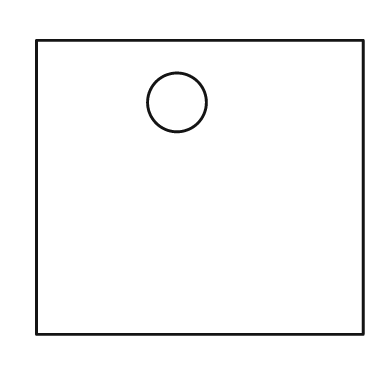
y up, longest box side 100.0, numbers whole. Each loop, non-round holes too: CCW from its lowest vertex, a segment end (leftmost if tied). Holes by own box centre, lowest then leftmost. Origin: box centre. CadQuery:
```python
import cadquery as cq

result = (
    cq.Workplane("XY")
    .moveTo(-50.0, -45.0)
    .lineTo(50.0, -45.0)
    .lineTo(50.0, 45.0)
    .lineTo(-50.0, 45.0)
    .close()
    .moveTo(-7.0, 26.0)
    .circle(9.0)
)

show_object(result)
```